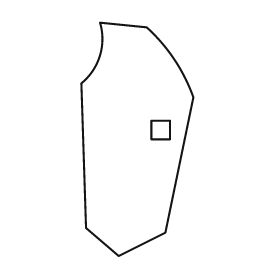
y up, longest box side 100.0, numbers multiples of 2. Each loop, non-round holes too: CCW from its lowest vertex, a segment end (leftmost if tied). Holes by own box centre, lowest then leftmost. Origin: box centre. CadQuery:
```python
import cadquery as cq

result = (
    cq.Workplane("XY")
    .moveTo(-8.0, -50.0)
    .lineTo(12.0, -40.0)
    .lineTo(24.0, 18.0)
    .threePointArc((16.0, 34.0), (4.0, 48.0))
    .lineTo(-16.0, 50.0)
    .threePointArc((-16.0, 36.0), (-24.0, 24.0))
    .lineTo(-22.0, -38.0)
    .close()
    .moveTo(6.0, 0.0)
    .lineTo(14.0, 0.0)
    .lineTo(14.0, 8.0)
    .lineTo(6.0, 8.0)
    .close()
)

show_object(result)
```